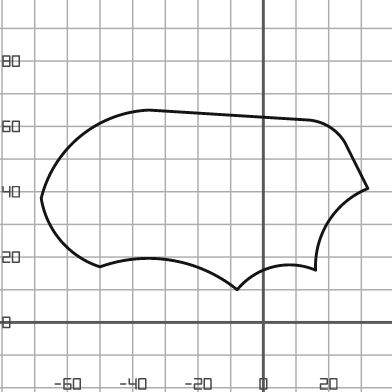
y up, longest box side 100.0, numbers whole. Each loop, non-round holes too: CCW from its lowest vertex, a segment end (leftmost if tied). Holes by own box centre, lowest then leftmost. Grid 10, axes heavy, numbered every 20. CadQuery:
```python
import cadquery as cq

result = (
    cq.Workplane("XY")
    .moveTo(-8.0, 10.0)
    .threePointArc((3.0, 17.0), (16.0, 16.0))
    .threePointArc((20.0, 31.0), (32.0, 41.0))
    .lineTo(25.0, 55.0)
    .threePointArc((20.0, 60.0), (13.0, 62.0))
    .lineTo(-35.0, 65.0)
    .threePointArc((-56.0, 57.0), (-68.0, 38.0))
    .threePointArc((-62.0, 25.0), (-50.0, 17.0))
    .threePointArc((-28.0, 19.0), (-8.0, 10.0))
    .close()
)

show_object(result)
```